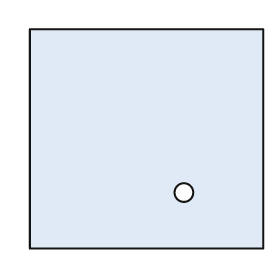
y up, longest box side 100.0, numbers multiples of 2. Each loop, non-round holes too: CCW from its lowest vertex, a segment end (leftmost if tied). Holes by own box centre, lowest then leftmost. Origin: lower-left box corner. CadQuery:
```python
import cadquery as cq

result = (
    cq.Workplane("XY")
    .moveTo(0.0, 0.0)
    .lineTo(100.0, 0.0)
    .lineTo(100.0, 94.0)
    .lineTo(0.0, 94.0)
    .close()
    .moveTo(66.0, 24.0)
    .circle(4.0)
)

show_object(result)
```